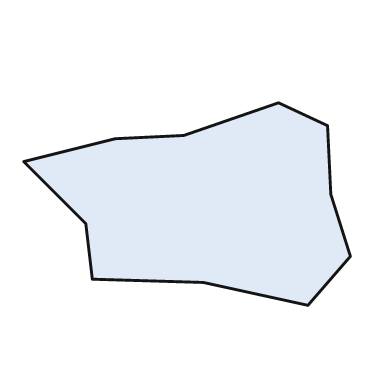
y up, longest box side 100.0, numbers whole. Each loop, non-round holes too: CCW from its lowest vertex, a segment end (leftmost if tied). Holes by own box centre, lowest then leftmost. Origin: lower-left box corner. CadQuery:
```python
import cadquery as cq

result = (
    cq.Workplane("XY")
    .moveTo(87.0, 0.0)
    .lineTo(100.0, 15.0)
    .lineTo(94.0, 34.0)
    .lineTo(93.0, 55.0)
    .lineTo(78.0, 62.0)
    .lineTo(49.0, 52.0)
    .lineTo(28.0, 51.0)
    .lineTo(0.0, 44.0)
    .lineTo(19.0, 25.0)
    .lineTo(21.0, 8.0)
    .lineTo(55.0, 7.0)
    .close()
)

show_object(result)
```